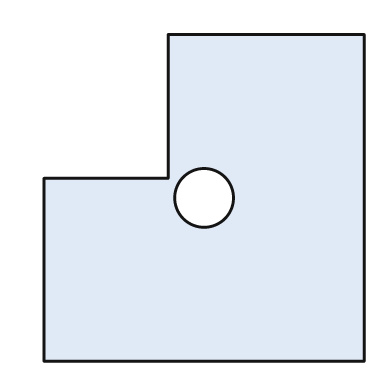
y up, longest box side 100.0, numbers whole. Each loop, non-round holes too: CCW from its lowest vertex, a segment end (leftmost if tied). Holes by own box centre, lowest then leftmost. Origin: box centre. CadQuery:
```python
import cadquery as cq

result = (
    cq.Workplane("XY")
    .moveTo(-49.0, -50.0)
    .lineTo(49.0, -50.0)
    .lineTo(49.0, 50.0)
    .lineTo(-11.0, 50.0)
    .lineTo(-11.0, 6.0)
    .lineTo(-49.0, 6.0)
    .close()
    .moveTo(0.0, 0.0)
    .circle(9.0)
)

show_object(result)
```